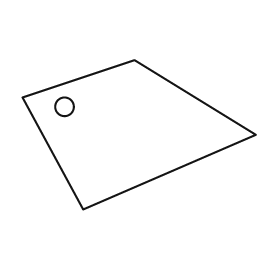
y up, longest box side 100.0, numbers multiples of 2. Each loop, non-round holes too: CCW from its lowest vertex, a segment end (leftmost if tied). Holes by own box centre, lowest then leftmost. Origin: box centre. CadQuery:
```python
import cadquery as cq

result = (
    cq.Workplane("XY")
    .moveTo(-24.0, -32.0)
    .lineTo(50.0, 0.0)
    .lineTo(-2.0, 32.0)
    .lineTo(-50.0, 16.0)
    .close()
    .moveTo(-32.0, 12.0)
    .circle(4.0)
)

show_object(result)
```